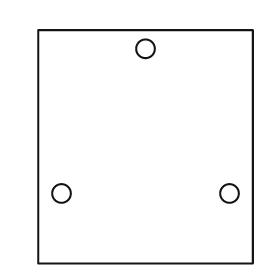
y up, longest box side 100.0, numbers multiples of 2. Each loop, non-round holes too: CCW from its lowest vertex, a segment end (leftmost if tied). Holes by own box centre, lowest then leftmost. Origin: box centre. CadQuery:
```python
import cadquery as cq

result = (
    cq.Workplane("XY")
    .moveTo(-46.0, -50.0)
    .lineTo(46.0, -50.0)
    .lineTo(46.0, 50.0)
    .lineTo(-46.0, 50.0)
    .close()
    .moveTo(-36.0, -20.0)
    .circle(4.0)
    .moveTo(36.0, -20.0)
    .circle(4.0)
    .moveTo(0.0, 42.0)
    .circle(4.0)
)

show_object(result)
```